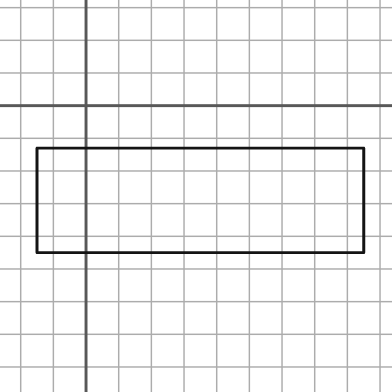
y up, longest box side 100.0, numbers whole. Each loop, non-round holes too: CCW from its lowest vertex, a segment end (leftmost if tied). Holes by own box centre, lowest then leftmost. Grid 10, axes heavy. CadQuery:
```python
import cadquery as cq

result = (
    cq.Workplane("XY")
    .moveTo(-15.0, -45.0)
    .lineTo(85.0, -45.0)
    .lineTo(85.0, -13.0)
    .lineTo(-15.0, -13.0)
    .close()
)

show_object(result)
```